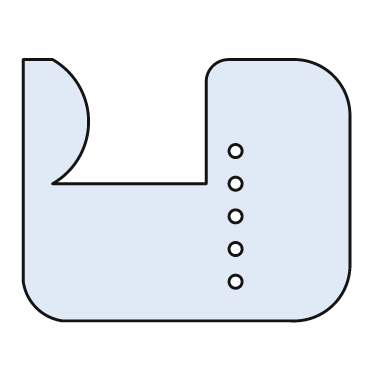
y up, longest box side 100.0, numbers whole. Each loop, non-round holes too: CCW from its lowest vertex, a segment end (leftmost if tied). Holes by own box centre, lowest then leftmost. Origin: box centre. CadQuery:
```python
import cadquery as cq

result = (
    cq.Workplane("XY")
    .moveTo(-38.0, -40.0)
    .lineTo(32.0, -40.0)
    .threePointArc((45.0, -35.0), (50.0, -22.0))
    .lineTo(50.0, 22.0)
    .threePointArc((45.0, 35.0), (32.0, 40.0))
    .lineTo(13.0, 40.0)
    .threePointArc((8.0, 38.0), (6.0, 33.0))
    .lineTo(6.0, 2.0)
    .lineTo(-41.0, 2.0)
    .threePointArc((-30.0, 21.0), (-41.0, 40.0))
    .lineTo(-50.0, 40.0)
    .lineTo(-50.0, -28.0)
    .threePointArc((-46.0, -36.0), (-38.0, -40.0))
    .close()
    .moveTo(15.0, -28.0)
    .circle(2.0)
    .moveTo(15.0, -18.0)
    .circle(2.0)
    .moveTo(15.0, -8.0)
    .circle(2.0)
    .moveTo(15.0, 2.0)
    .circle(2.0)
    .moveTo(15.0, 12.0)
    .circle(2.0)
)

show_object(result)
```